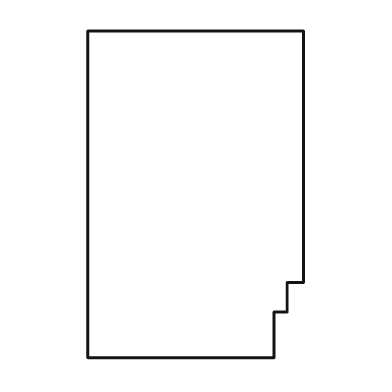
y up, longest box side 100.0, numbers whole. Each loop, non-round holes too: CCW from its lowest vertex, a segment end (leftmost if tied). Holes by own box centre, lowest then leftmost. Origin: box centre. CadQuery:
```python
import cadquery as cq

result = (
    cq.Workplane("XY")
    .moveTo(-33.0, -50.0)
    .lineTo(24.0, -50.0)
    .lineTo(24.0, -36.0)
    .lineTo(28.0, -36.0)
    .lineTo(28.0, -27.0)
    .lineTo(33.0, -27.0)
    .lineTo(33.0, 50.0)
    .lineTo(-33.0, 50.0)
    .close()
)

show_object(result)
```